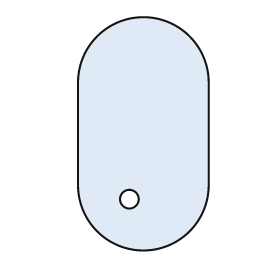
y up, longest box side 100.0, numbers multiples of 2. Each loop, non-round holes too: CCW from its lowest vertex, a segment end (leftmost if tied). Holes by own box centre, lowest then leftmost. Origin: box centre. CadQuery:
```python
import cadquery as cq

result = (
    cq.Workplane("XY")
    .moveTo(-28.0, -22.0)
    .threePointArc((0.0, -50.0), (28.0, -22.0))
    .lineTo(28.0, 22.0)
    .threePointArc((0.0, 50.0), (-28.0, 22.0))
    .close()
    .moveTo(-6.0, -28.0)
    .circle(4.0)
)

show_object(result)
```